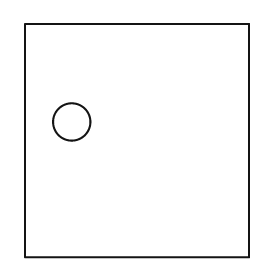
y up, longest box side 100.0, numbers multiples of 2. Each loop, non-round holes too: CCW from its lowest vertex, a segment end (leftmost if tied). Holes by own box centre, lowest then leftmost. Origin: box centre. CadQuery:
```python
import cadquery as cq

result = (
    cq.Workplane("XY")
    .moveTo(-48.0, -50.0)
    .lineTo(48.0, -50.0)
    .lineTo(48.0, 50.0)
    .lineTo(-48.0, 50.0)
    .close()
    .moveTo(-28.0, 8.0)
    .circle(8.0)
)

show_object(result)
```